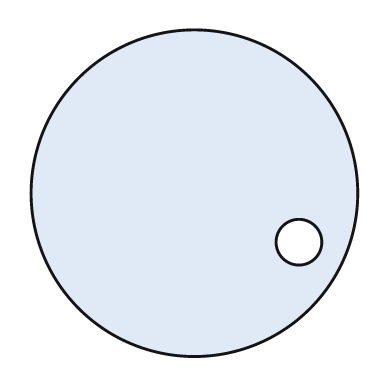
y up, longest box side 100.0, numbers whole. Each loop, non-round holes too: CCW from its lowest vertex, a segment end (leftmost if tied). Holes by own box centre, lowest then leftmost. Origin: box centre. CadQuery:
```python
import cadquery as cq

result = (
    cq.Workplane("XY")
    .moveTo(0.0, 0.0)
    .circle(50.0)
    .moveTo(32.0, -15.0)
    .circle(7.0)
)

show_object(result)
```